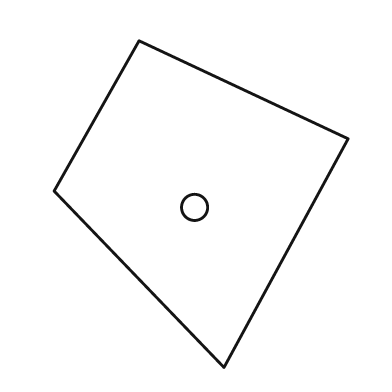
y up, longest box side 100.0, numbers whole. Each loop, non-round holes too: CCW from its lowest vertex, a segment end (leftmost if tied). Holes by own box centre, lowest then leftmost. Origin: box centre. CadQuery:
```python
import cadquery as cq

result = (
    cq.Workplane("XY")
    .moveTo(7.0, -50.0)
    .lineTo(45.0, 20.0)
    .lineTo(-19.0, 50.0)
    .lineTo(-45.0, 4.0)
    .close()
    .moveTo(-2.0, -1.0)
    .circle(4.0)
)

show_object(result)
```